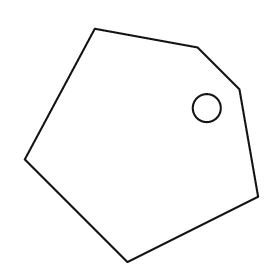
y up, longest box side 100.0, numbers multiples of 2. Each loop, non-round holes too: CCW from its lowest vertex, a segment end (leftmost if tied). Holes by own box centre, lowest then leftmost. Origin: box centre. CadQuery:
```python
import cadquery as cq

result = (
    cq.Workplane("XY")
    .moveTo(-6.0, -50.0)
    .lineTo(50.0, -22.0)
    .lineTo(42.0, 24.0)
    .lineTo(24.0, 42.0)
    .lineTo(-20.0, 50.0)
    .lineTo(-50.0, -6.0)
    .close()
    .moveTo(28.0, 16.0)
    .circle(6.0)
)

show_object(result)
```